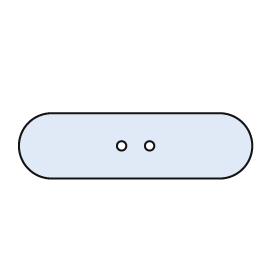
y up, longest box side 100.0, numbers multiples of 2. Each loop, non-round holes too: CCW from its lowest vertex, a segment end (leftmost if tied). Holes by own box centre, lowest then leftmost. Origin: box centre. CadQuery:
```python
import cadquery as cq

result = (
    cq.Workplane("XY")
    .moveTo(-36.0, -14.0)
    .lineTo(36.0, -14.0)
    .threePointArc((50.0, 0.0), (36.0, 14.0))
    .lineTo(-36.0, 14.0)
    .threePointArc((-50.0, 0.0), (-36.0, -14.0))
    .close()
    .moveTo(-6.0, 0.0)
    .circle(2.0)
    .moveTo(6.0, 0.0)
    .circle(2.0)
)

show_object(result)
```